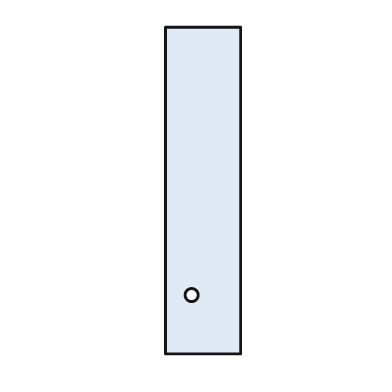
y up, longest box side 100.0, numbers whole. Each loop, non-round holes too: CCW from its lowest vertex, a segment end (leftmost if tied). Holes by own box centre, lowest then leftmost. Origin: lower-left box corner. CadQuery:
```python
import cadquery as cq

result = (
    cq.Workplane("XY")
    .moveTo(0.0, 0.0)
    .lineTo(23.0, 0.0)
    .lineTo(23.0, 100.0)
    .lineTo(0.0, 100.0)
    .close()
    .moveTo(8.0, 18.0)
    .circle(2.0)
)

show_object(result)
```